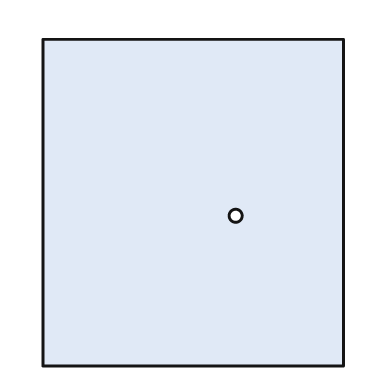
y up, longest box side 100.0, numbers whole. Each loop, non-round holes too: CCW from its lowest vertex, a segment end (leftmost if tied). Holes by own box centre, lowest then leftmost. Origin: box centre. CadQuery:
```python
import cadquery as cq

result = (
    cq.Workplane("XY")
    .moveTo(-46.0, -50.0)
    .lineTo(46.0, -50.0)
    .lineTo(46.0, 50.0)
    .lineTo(-46.0, 50.0)
    .close()
    .moveTo(13.0, -4.0)
    .circle(2.0)
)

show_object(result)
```